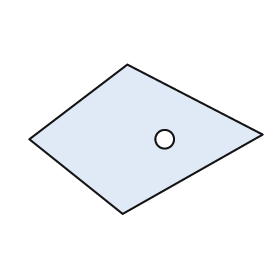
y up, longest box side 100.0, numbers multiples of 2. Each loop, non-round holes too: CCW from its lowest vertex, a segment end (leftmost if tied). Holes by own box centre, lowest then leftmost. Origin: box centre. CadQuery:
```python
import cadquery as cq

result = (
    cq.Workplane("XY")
    .moveTo(-10.0, -32.0)
    .lineTo(50.0, 2.0)
    .lineTo(-8.0, 32.0)
    .lineTo(-50.0, 0.0)
    .close()
    .moveTo(8.0, 0.0)
    .circle(4.0)
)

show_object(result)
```